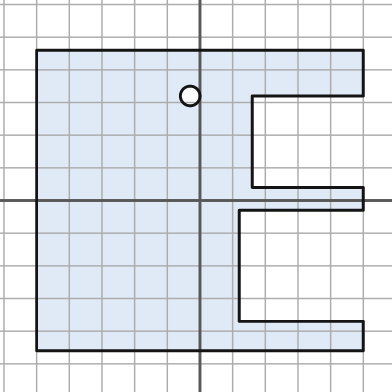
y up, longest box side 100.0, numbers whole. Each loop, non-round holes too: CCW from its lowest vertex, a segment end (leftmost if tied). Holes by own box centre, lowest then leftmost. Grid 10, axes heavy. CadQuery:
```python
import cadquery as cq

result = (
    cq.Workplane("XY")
    .moveTo(-50.0, -46.0)
    .lineTo(50.0, -46.0)
    .lineTo(50.0, -37.0)
    .lineTo(12.0, -37.0)
    .lineTo(12.0, -3.0)
    .lineTo(50.0, -3.0)
    .lineTo(50.0, 4.0)
    .lineTo(16.0, 4.0)
    .lineTo(16.0, 32.0)
    .lineTo(50.0, 32.0)
    .lineTo(50.0, 46.0)
    .lineTo(-50.0, 46.0)
    .close()
    .moveTo(-3.0, 32.0)
    .circle(3.0)
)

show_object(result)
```